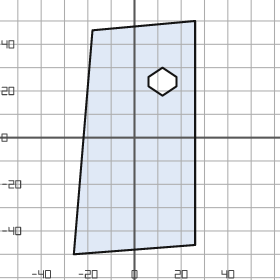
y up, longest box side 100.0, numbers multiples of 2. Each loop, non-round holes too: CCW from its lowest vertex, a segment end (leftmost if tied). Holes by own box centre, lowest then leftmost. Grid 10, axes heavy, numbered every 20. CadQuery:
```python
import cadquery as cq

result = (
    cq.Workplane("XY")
    .moveTo(-26.0, -50.0)
    .lineTo(26.0, -46.0)
    .lineTo(26.0, 50.0)
    .lineTo(-18.0, 46.0)
    .close()
    .moveTo(12.0, 18.0)
    .lineTo(18.0, 22.0)
    .lineTo(18.0, 26.0)
    .lineTo(12.0, 30.0)
    .lineTo(6.0, 26.0)
    .lineTo(6.0, 22.0)
    .close()
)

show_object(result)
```